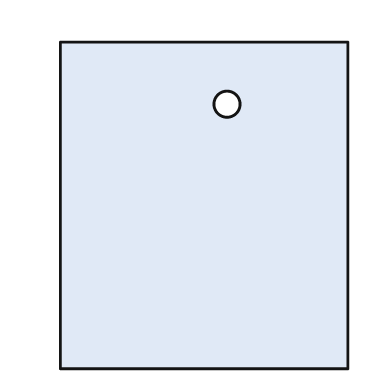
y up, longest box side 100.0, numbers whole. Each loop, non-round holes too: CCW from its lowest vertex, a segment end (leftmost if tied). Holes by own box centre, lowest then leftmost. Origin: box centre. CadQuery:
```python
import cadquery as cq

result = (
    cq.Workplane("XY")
    .moveTo(-44.0, -50.0)
    .lineTo(44.0, -50.0)
    .lineTo(44.0, 50.0)
    .lineTo(-44.0, 50.0)
    .close()
    .moveTo(7.0, 31.0)
    .circle(4.0)
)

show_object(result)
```